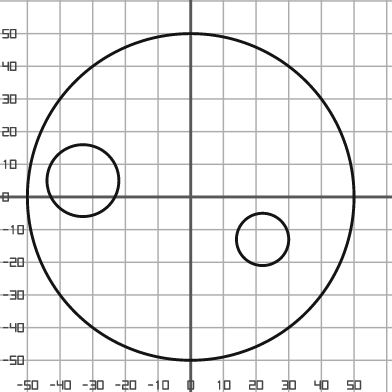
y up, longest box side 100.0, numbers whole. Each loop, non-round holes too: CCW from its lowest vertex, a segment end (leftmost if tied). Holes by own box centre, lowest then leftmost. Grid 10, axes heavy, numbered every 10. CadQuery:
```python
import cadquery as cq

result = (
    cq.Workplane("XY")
    .moveTo(0.0, 0.0)
    .circle(50.0)
    .moveTo(22.0, -13.0)
    .circle(8.0)
    .moveTo(-33.0, 5.0)
    .circle(11.0)
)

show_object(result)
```